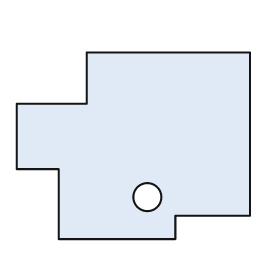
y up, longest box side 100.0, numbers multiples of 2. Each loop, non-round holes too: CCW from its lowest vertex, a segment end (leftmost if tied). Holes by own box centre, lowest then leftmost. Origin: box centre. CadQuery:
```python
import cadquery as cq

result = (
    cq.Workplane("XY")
    .moveTo(-32.0, -40.0)
    .lineTo(18.0, -40.0)
    .lineTo(18.0, -30.0)
    .lineTo(50.0, -30.0)
    .lineTo(50.0, 40.0)
    .lineTo(-20.0, 40.0)
    .lineTo(-20.0, 18.0)
    .lineTo(-50.0, 18.0)
    .lineTo(-50.0, -10.0)
    .lineTo(-32.0, -10.0)
    .close()
    .moveTo(6.0, -22.0)
    .circle(6.0)
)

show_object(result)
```